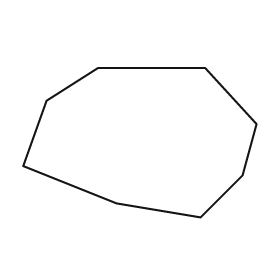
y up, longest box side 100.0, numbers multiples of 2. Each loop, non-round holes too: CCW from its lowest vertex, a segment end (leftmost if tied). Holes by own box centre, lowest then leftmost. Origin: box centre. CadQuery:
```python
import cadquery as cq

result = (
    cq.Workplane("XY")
    .moveTo(26.0, -32.0)
    .lineTo(44.0, -14.0)
    .lineTo(50.0, 8.0)
    .lineTo(28.0, 32.0)
    .lineTo(-18.0, 32.0)
    .lineTo(-40.0, 18.0)
    .lineTo(-50.0, -10.0)
    .lineTo(-10.0, -26.0)
    .close()
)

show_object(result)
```